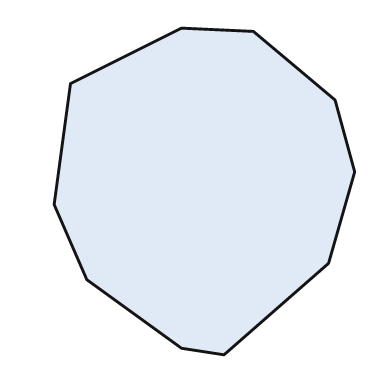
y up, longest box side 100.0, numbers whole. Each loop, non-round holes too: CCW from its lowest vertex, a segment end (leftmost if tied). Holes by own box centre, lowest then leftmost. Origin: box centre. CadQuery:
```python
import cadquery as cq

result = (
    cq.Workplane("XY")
    .moveTo(6.0, -50.0)
    .lineTo(38.0, -22.0)
    .lineTo(46.0, 6.0)
    .lineTo(40.0, 28.0)
    .lineTo(15.0, 49.0)
    .lineTo(-7.0, 50.0)
    .lineTo(-41.0, 33.0)
    .lineTo(-46.0, -4.0)
    .lineTo(-36.0, -27.0)
    .lineTo(-7.0, -48.0)
    .close()
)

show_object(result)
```